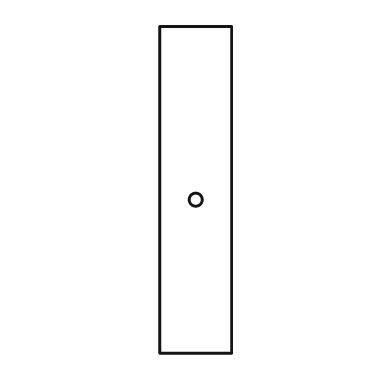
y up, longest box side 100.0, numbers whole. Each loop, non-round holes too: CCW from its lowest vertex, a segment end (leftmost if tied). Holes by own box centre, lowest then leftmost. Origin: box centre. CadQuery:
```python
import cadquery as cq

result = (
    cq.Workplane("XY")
    .moveTo(-11.0, -50.0)
    .lineTo(11.0, -50.0)
    .lineTo(11.0, 50.0)
    .lineTo(-11.0, 50.0)
    .close()
    .moveTo(0.0, -3.0)
    .circle(2.0)
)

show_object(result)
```